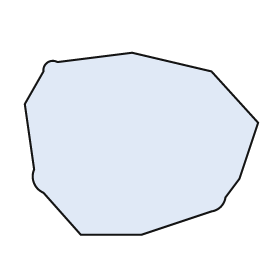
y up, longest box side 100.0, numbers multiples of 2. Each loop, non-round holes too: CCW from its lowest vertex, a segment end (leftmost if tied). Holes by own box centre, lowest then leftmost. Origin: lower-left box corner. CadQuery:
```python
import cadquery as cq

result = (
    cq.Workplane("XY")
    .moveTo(24.0, 0.0)
    .lineTo(50.0, 0.0)
    .lineTo(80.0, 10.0)
    .threePointArc((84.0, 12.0), (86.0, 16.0))
    .lineTo(92.0, 24.0)
    .lineTo(100.0, 48.0)
    .lineTo(80.0, 70.0)
    .lineTo(46.0, 78.0)
    .lineTo(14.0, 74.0)
    .threePointArc((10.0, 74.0), (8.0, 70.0))
    .lineTo(0.0, 56.0)
    .lineTo(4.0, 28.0)
    .threePointArc((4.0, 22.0), (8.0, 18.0))
    .close()
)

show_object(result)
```